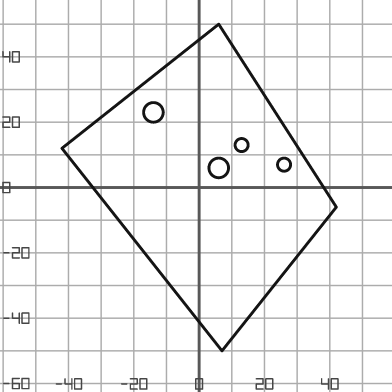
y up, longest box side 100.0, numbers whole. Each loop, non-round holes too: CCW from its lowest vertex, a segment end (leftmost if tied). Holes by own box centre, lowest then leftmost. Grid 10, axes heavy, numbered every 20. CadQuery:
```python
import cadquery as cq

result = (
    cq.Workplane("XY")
    .moveTo(7.0, -50.0)
    .lineTo(42.0, -6.0)
    .lineTo(6.0, 50.0)
    .lineTo(-42.0, 12.0)
    .close()
    .moveTo(6.0, 6.0)
    .circle(3.0)
    .moveTo(26.0, 7.0)
    .circle(2.0)
    .moveTo(13.0, 13.0)
    .circle(2.0)
    .moveTo(-14.0, 23.0)
    .circle(3.0)
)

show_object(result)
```